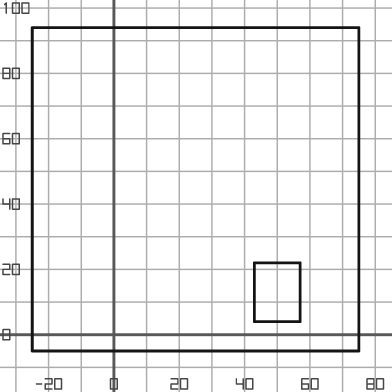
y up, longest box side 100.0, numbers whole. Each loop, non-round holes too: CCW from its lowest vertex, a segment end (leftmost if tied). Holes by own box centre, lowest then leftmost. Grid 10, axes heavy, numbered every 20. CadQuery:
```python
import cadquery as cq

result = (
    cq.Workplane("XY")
    .moveTo(-25.0, -5.0)
    .lineTo(75.0, -5.0)
    .lineTo(75.0, 94.0)
    .lineTo(-25.0, 94.0)
    .close()
    .moveTo(43.0, 4.0)
    .lineTo(57.0, 4.0)
    .lineTo(57.0, 22.0)
    .lineTo(43.0, 22.0)
    .close()
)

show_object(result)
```